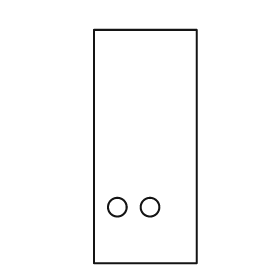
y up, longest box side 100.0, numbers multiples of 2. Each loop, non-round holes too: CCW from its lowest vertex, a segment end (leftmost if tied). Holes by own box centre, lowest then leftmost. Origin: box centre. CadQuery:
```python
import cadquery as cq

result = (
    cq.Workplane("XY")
    .moveTo(-22.0, -50.0)
    .lineTo(22.0, -50.0)
    .lineTo(22.0, 50.0)
    .lineTo(-22.0, 50.0)
    .close()
    .moveTo(-12.0, -26.0)
    .circle(4.0)
    .moveTo(2.0, -26.0)
    .circle(4.0)
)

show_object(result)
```